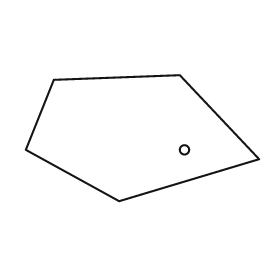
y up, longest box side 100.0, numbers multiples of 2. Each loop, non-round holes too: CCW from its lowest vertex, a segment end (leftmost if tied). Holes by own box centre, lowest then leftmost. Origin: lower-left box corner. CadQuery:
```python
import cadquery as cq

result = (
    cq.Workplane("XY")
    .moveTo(40.0, 0.0)
    .lineTo(100.0, 18.0)
    .lineTo(66.0, 54.0)
    .lineTo(12.0, 52.0)
    .lineTo(0.0, 22.0)
    .close()
    .moveTo(68.0, 22.0)
    .circle(2.0)
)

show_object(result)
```